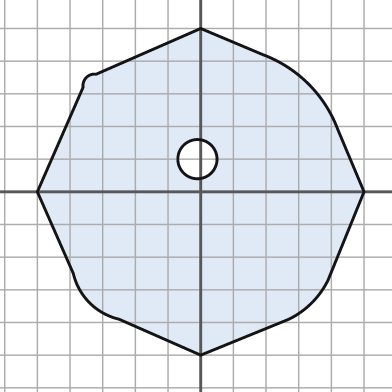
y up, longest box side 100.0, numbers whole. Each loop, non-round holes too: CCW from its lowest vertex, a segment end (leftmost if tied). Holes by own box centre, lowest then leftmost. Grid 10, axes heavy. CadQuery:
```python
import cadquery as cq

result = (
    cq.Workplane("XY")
    .moveTo(0.0, -50.0)
    .lineTo(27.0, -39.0)
    .threePointArc((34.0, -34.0), (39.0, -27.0))
    .lineTo(50.0, 0.0)
    .lineTo(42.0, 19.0)
    .threePointArc((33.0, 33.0), (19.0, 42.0))
    .lineTo(0.0, 50.0)
    .lineTo(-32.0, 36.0)
    .threePointArc((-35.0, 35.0), (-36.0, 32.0))
    .lineTo(-50.0, 0.0)
    .lineTo(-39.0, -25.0)
    .threePointArc((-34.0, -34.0), (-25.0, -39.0))
    .close()
    .moveTo(-1.0, 10.0)
    .circle(6.0)
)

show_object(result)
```